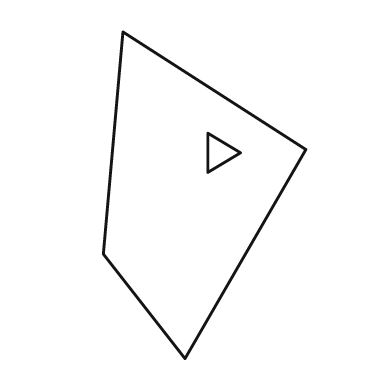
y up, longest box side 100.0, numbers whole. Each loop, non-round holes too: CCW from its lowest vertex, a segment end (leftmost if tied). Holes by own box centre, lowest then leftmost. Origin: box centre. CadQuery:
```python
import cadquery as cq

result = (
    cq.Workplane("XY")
    .moveTo(-6.0, -50.0)
    .lineTo(31.0, 14.0)
    .lineTo(-25.0, 50.0)
    .lineTo(-31.0, -18.0)
    .close()
    .moveTo(1.0, 7.0)
    .lineTo(11.0, 13.0)
    .lineTo(1.0, 19.0)
    .close()
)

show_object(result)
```